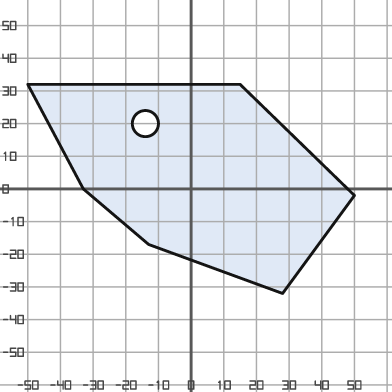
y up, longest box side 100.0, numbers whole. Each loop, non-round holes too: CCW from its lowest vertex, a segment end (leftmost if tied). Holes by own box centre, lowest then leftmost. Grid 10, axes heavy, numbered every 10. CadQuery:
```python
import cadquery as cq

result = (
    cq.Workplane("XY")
    .moveTo(28.0, -32.0)
    .lineTo(50.0, -2.0)
    .lineTo(15.0, 32.0)
    .lineTo(-50.0, 32.0)
    .lineTo(-33.0, 0.0)
    .lineTo(-13.0, -17.0)
    .close()
    .moveTo(-14.0, 20.0)
    .circle(4.0)
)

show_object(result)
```